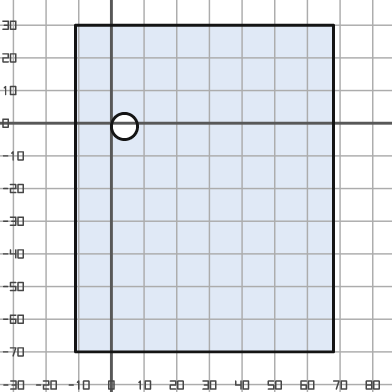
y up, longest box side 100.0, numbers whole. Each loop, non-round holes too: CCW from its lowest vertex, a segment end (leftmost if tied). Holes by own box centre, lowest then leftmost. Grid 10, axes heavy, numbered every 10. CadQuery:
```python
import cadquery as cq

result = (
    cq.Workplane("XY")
    .moveTo(-11.0, -70.0)
    .lineTo(68.0, -70.0)
    .lineTo(68.0, 30.0)
    .lineTo(-11.0, 30.0)
    .close()
    .moveTo(4.0, -1.0)
    .circle(4.0)
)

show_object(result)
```